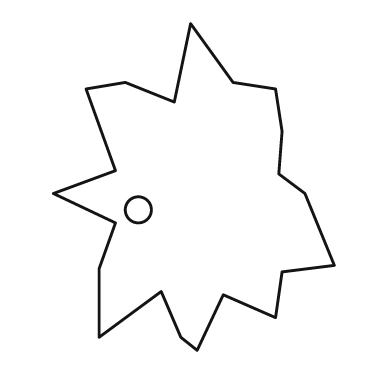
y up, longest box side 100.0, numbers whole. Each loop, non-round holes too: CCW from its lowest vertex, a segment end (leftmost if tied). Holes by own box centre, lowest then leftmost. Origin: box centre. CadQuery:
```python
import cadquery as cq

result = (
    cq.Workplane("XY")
    .moveTo(1.0, -50.0)
    .lineTo(9.0, -33.0)
    .lineTo(25.0, -40.0)
    .lineTo(27.0, -26.0)
    .lineTo(43.0, -24.0)
    .lineTo(34.0, -2.0)
    .lineTo(26.0, 4.0)
    .lineTo(27.0, 17.0)
    .lineTo(25.0, 30.0)
    .lineTo(12.0, 32.0)
    .lineTo(-1.0, 50.0)
    .lineTo(-6.0, 26.0)
    .lineTo(-21.0, 32.0)
    .lineTo(-33.0, 30.0)
    .lineTo(-24.0, 5.0)
    .lineTo(-43.0, -2.0)
    .lineTo(-24.0, -11.0)
    .lineTo(-29.0, -25.0)
    .lineTo(-29.0, -46.0)
    .lineTo(-10.0, -32.0)
    .lineTo(-4.0, -46.0)
    .close()
    .moveTo(-17.0, -7.0)
    .circle(4.0)
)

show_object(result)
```